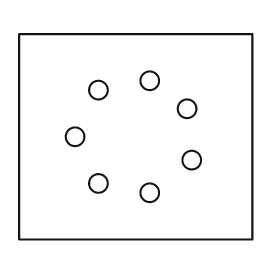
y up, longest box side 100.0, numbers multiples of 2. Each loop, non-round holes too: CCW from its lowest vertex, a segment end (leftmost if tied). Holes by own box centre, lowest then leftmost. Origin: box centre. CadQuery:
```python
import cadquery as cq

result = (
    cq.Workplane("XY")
    .moveTo(-50.0, -44.0)
    .lineTo(50.0, -44.0)
    .lineTo(50.0, 44.0)
    .lineTo(-50.0, 44.0)
    .close()
    .moveTo(6.0, -24.0)
    .circle(4.0)
    .moveTo(-16.0, -20.0)
    .circle(4.0)
    .moveTo(24.0, -10.0)
    .circle(4.0)
    .moveTo(-26.0, 0.0)
    .circle(4.0)
    .moveTo(22.0, 12.0)
    .circle(4.0)
    .moveTo(-16.0, 20.0)
    .circle(4.0)
    .moveTo(6.0, 24.0)
    .circle(4.0)
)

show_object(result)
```